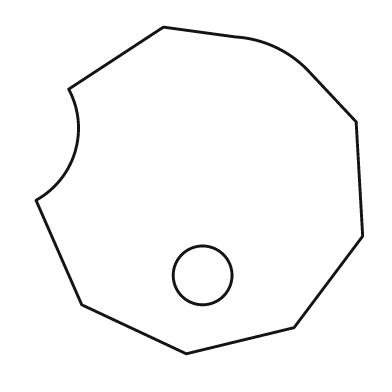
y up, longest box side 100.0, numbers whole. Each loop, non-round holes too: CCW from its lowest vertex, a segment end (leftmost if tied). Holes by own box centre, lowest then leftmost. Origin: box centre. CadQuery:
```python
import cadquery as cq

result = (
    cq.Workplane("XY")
    .moveTo(-4.0, -50.0)
    .lineTo(29.0, -42.0)
    .lineTo(50.0, -14.0)
    .lineTo(48.0, 21.0)
    .lineTo(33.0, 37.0)
    .threePointArc((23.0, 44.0), (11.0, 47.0))
    .lineTo(-11.0, 50.0)
    .lineTo(-40.0, 31.0)
    .threePointArc((-38.0, 12.0), (-50.0, -3.0))
    .lineTo(-36.0, -35.0)
    .close()
    .moveTo(1.0, -26.0)
    .circle(9.0)
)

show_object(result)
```